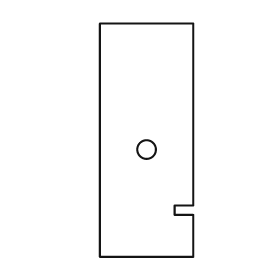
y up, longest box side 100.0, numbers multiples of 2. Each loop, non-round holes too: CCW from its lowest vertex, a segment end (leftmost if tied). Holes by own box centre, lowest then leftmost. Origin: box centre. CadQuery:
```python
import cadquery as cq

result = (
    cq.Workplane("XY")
    .moveTo(-20.0, -50.0)
    .lineTo(20.0, -50.0)
    .lineTo(20.0, -32.0)
    .lineTo(12.0, -32.0)
    .lineTo(12.0, -28.0)
    .lineTo(20.0, -28.0)
    .lineTo(20.0, 50.0)
    .lineTo(-20.0, 50.0)
    .close()
    .moveTo(0.0, -4.0)
    .circle(4.0)
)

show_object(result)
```